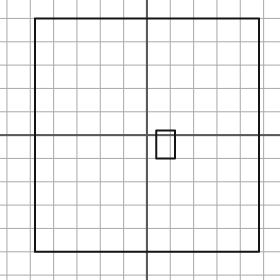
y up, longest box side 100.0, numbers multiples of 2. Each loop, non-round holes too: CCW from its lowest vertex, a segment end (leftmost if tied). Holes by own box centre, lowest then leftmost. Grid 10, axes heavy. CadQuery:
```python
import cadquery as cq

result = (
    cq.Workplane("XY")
    .moveTo(-48.0, -50.0)
    .lineTo(48.0, -50.0)
    .lineTo(48.0, 50.0)
    .lineTo(-48.0, 50.0)
    .close()
    .moveTo(4.0, -10.0)
    .lineTo(12.0, -10.0)
    .lineTo(12.0, 2.0)
    .lineTo(4.0, 2.0)
    .close()
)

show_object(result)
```